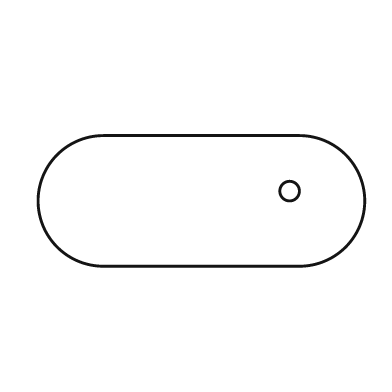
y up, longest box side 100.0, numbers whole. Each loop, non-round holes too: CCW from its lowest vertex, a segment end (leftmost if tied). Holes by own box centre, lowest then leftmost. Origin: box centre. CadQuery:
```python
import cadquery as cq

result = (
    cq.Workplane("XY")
    .moveTo(-30.0, -20.0)
    .lineTo(30.0, -20.0)
    .threePointArc((50.0, 0.0), (30.0, 20.0))
    .lineTo(-30.0, 20.0)
    .threePointArc((-50.0, 0.0), (-30.0, -20.0))
    .close()
    .moveTo(27.0, 3.0)
    .circle(3.0)
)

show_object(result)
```